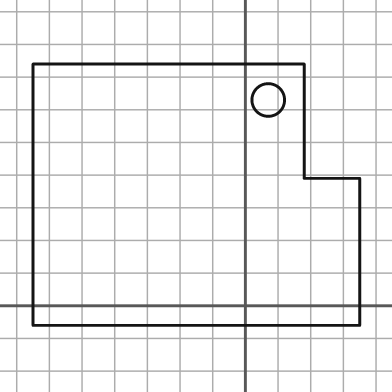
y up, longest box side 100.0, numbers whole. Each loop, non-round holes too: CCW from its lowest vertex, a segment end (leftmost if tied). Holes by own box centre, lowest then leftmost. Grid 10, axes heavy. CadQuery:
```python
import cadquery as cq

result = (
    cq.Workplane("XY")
    .moveTo(-65.0, -6.0)
    .lineTo(35.0, -6.0)
    .lineTo(35.0, 39.0)
    .lineTo(18.0, 39.0)
    .lineTo(18.0, 74.0)
    .lineTo(-65.0, 74.0)
    .close()
    .moveTo(7.0, 63.0)
    .circle(5.0)
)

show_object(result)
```